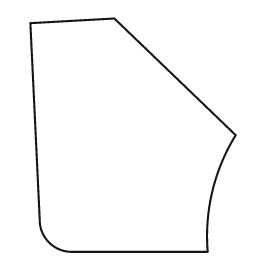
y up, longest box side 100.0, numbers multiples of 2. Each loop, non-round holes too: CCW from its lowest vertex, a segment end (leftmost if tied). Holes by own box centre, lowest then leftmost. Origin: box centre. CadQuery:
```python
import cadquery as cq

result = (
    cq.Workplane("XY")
    .moveTo(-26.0, -50.0)
    .lineTo(32.0, -50.0)
    .threePointArc((34.0, -24.0), (44.0, 0.0))
    .lineTo(-8.0, 50.0)
    .lineTo(-44.0, 48.0)
    .lineTo(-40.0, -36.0)
    .threePointArc((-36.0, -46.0), (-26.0, -50.0))
    .close()
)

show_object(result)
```